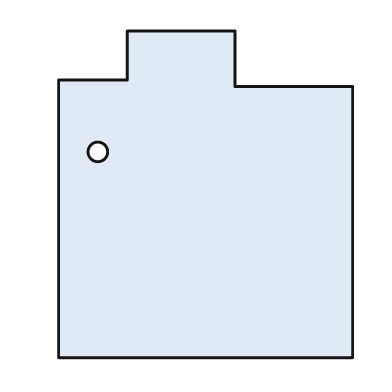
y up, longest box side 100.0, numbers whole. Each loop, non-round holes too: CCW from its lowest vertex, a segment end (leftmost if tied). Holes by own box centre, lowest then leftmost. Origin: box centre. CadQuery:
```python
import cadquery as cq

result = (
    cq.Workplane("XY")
    .moveTo(-45.0, -50.0)
    .lineTo(45.0, -50.0)
    .lineTo(45.0, 33.0)
    .lineTo(9.0, 33.0)
    .lineTo(9.0, 50.0)
    .lineTo(-24.0, 50.0)
    .lineTo(-24.0, 35.0)
    .lineTo(-45.0, 35.0)
    .close()
    .moveTo(-33.0, 13.0)
    .circle(3.0)
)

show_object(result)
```